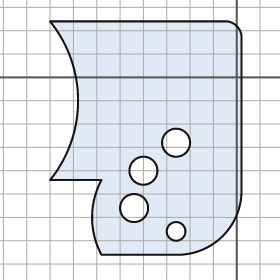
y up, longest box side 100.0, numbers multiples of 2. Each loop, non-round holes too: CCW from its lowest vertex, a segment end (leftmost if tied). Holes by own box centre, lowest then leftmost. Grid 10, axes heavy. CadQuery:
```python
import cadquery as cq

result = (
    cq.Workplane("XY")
    .moveTo(-58.0, -76.0)
    .lineTo(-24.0, -76.0)
    .threePointArc((-6.0, -68.0), (2.0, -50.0))
    .lineTo(2.0, 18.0)
    .threePointArc((0.0, 22.0), (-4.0, 24.0))
    .lineTo(-80.0, 24.0)
    .threePointArc((-68.0, -10.0), (-80.0, -44.0))
    .lineTo(-58.0, -44.0)
    .threePointArc((-62.0, -60.0), (-58.0, -76.0))
    .close()
    .moveTo(-26.0, -66.0)
    .circle(4.0)
    .moveTo(-44.0, -56.0)
    .circle(6.0)
    .moveTo(-40.0, -40.0)
    .circle(6.0)
    .moveTo(-26.0, -28.0)
    .circle(6.0)
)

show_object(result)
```